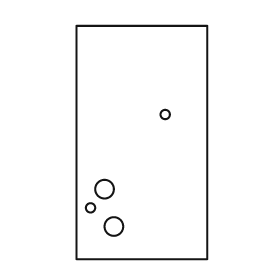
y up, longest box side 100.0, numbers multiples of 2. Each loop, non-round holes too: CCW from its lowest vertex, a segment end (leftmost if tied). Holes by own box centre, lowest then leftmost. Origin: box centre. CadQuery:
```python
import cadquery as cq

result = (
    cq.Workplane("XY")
    .moveTo(-28.0, -50.0)
    .lineTo(28.0, -50.0)
    .lineTo(28.0, 50.0)
    .lineTo(-28.0, 50.0)
    .close()
    .moveTo(-12.0, -36.0)
    .circle(4.0)
    .moveTo(-22.0, -28.0)
    .circle(2.0)
    .moveTo(-16.0, -20.0)
    .circle(4.0)
    .moveTo(10.0, 12.0)
    .circle(2.0)
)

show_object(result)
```